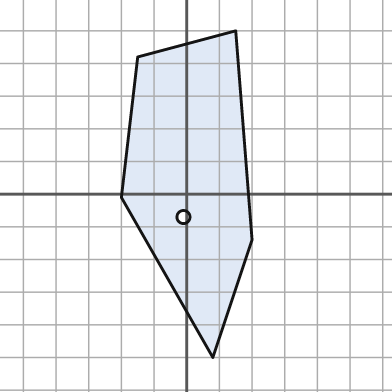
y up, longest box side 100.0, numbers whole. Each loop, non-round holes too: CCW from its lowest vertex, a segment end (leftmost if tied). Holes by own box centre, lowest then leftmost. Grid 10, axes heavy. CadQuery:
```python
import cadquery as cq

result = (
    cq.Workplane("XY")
    .moveTo(8.0, -50.0)
    .lineTo(20.0, -14.0)
    .lineTo(15.0, 50.0)
    .lineTo(-15.0, 42.0)
    .lineTo(-20.0, -1.0)
    .close()
    .moveTo(-1.0, -7.0)
    .circle(2.0)
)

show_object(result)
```